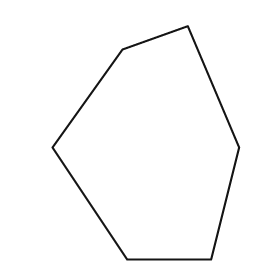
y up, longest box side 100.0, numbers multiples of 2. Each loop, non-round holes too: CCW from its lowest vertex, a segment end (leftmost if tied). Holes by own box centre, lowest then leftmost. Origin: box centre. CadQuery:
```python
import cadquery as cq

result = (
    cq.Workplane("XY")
    .moveTo(-8.0, -50.0)
    .lineTo(28.0, -50.0)
    .lineTo(40.0, -2.0)
    .lineTo(18.0, 50.0)
    .lineTo(-10.0, 40.0)
    .lineTo(-40.0, -2.0)
    .close()
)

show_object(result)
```